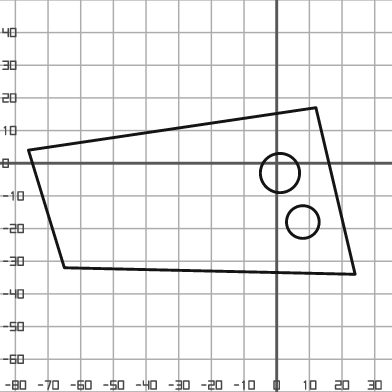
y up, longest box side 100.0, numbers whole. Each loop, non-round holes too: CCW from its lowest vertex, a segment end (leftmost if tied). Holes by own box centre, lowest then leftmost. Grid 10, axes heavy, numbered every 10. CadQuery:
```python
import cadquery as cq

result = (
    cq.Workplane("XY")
    .moveTo(24.0, -34.0)
    .lineTo(12.0, 17.0)
    .lineTo(-76.0, 4.0)
    .lineTo(-65.0, -32.0)
    .close()
    .moveTo(8.0, -18.0)
    .circle(5.0)
    .moveTo(1.0, -3.0)
    .circle(6.0)
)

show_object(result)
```